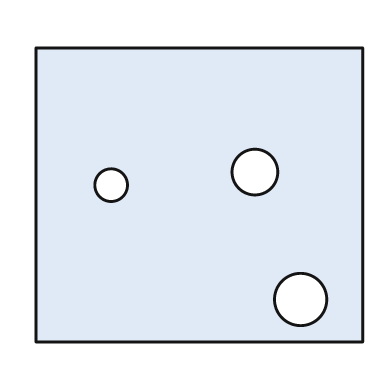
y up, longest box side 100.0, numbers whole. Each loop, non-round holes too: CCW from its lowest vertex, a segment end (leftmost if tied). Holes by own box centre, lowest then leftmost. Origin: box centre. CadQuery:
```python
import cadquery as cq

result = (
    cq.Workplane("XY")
    .moveTo(-50.0, -45.0)
    .lineTo(50.0, -45.0)
    .lineTo(50.0, 45.0)
    .lineTo(-50.0, 45.0)
    .close()
    .moveTo(31.0, -32.0)
    .circle(8.0)
    .moveTo(-27.0, 3.0)
    .circle(5.0)
    .moveTo(17.0, 7.0)
    .circle(7.0)
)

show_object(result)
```